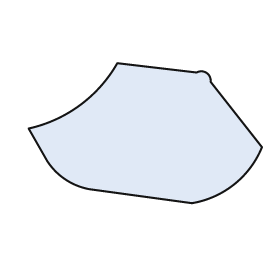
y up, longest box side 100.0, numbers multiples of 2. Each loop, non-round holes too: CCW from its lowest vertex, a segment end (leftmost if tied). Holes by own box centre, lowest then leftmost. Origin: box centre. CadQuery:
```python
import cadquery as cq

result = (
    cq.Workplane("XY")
    .moveTo(20.0, -30.0)
    .threePointArc((38.0, -22.0), (50.0, -6.0))
    .lineTo(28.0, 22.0)
    .threePointArc((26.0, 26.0), (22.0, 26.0))
    .lineTo(-12.0, 30.0)
    .threePointArc((-28.0, 12.0), (-50.0, 2.0))
    .lineTo(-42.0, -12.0)
    .threePointArc((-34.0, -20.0), (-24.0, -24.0))
    .close()
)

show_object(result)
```